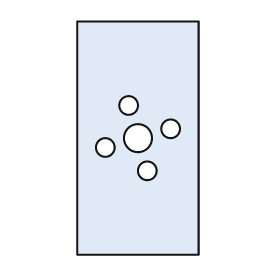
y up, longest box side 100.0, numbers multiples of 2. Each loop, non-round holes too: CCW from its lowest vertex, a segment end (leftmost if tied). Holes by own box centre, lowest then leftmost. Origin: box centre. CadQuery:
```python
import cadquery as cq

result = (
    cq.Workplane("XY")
    .moveTo(-26.0, -50.0)
    .lineTo(26.0, -50.0)
    .lineTo(26.0, 50.0)
    .lineTo(-26.0, 50.0)
    .close()
    .moveTo(4.0, -14.0)
    .circle(4.0)
    .moveTo(-14.0, -4.0)
    .circle(4.0)
    .moveTo(0.0, 0.0)
    .circle(6.0)
    .moveTo(14.0, 4.0)
    .circle(4.0)
    .moveTo(-4.0, 14.0)
    .circle(4.0)
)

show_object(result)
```